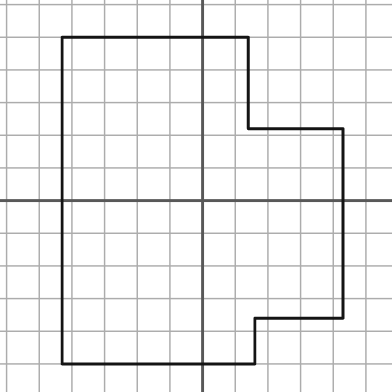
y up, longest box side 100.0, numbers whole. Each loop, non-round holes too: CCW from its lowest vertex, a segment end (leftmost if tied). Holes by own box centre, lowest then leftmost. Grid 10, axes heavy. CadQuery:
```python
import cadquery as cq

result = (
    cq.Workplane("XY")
    .moveTo(-43.0, -50.0)
    .lineTo(16.0, -50.0)
    .lineTo(16.0, -36.0)
    .lineTo(43.0, -36.0)
    .lineTo(43.0, 22.0)
    .lineTo(14.0, 22.0)
    .lineTo(14.0, 50.0)
    .lineTo(-43.0, 50.0)
    .close()
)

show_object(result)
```